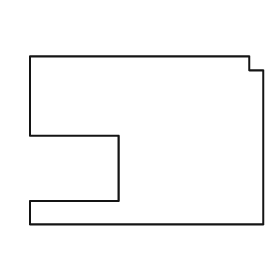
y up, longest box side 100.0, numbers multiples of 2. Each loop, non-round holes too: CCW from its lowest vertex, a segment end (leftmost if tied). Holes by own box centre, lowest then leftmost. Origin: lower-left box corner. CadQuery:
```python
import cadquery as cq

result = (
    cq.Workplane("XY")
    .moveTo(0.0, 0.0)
    .lineTo(100.0, 0.0)
    .lineTo(100.0, 66.0)
    .lineTo(94.0, 66.0)
    .lineTo(94.0, 72.0)
    .lineTo(0.0, 72.0)
    .lineTo(0.0, 38.0)
    .lineTo(38.0, 38.0)
    .lineTo(38.0, 10.0)
    .lineTo(0.0, 10.0)
    .close()
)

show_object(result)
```